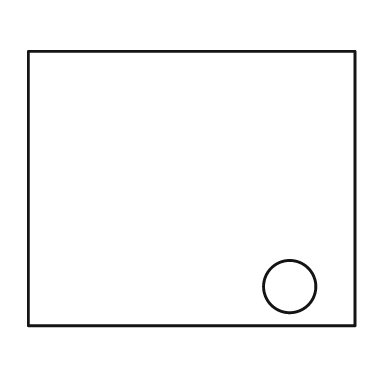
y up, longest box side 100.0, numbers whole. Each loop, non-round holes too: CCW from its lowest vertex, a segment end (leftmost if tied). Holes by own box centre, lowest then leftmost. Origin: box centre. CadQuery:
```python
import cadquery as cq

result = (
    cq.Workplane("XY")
    .moveTo(-50.0, -42.0)
    .lineTo(50.0, -42.0)
    .lineTo(50.0, 42.0)
    .lineTo(-50.0, 42.0)
    .close()
    .moveTo(30.0, -30.0)
    .circle(8.0)
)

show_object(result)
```